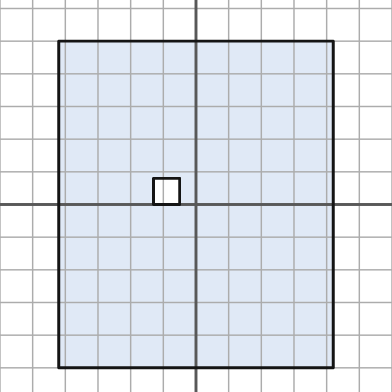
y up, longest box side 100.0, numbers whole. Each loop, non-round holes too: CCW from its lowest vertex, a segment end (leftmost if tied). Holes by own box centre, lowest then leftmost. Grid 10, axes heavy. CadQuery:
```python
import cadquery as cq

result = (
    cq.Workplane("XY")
    .moveTo(-42.0, -50.0)
    .lineTo(42.0, -50.0)
    .lineTo(42.0, 50.0)
    .lineTo(-42.0, 50.0)
    .close()
    .moveTo(-13.0, 0.0)
    .lineTo(-5.0, 0.0)
    .lineTo(-5.0, 8.0)
    .lineTo(-13.0, 8.0)
    .close()
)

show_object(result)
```